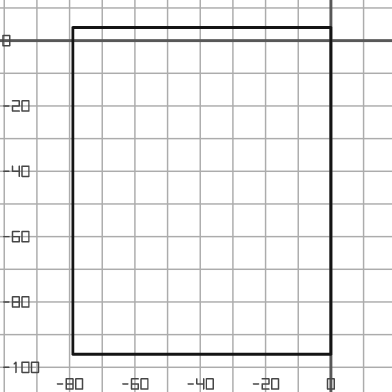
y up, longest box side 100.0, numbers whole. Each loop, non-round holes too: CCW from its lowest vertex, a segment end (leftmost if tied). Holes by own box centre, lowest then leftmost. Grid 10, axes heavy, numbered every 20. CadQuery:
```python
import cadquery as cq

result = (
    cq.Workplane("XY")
    .moveTo(-79.0, -96.0)
    .lineTo(0.0, -96.0)
    .lineTo(0.0, 4.0)
    .lineTo(-79.0, 4.0)
    .close()
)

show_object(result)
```